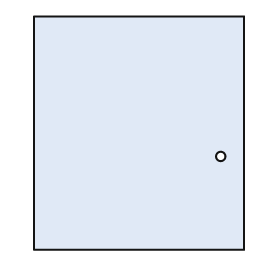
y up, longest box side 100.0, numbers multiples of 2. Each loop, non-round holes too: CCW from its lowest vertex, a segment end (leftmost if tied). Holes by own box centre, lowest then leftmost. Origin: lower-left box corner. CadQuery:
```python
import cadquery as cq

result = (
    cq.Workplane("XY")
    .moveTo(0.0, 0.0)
    .lineTo(90.0, 0.0)
    .lineTo(90.0, 100.0)
    .lineTo(0.0, 100.0)
    .close()
    .moveTo(80.0, 40.0)
    .circle(2.0)
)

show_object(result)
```